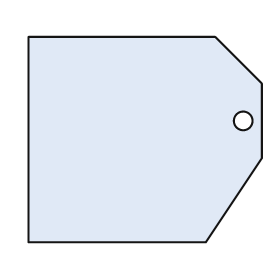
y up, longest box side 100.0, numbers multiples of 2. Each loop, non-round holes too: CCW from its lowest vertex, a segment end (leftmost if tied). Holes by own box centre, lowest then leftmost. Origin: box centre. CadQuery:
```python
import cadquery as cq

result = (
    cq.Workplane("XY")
    .moveTo(-50.0, -44.0)
    .lineTo(26.0, -44.0)
    .lineTo(50.0, -8.0)
    .lineTo(50.0, 24.0)
    .lineTo(30.0, 44.0)
    .lineTo(-50.0, 44.0)
    .close()
    .moveTo(42.0, 8.0)
    .circle(4.0)
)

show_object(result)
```